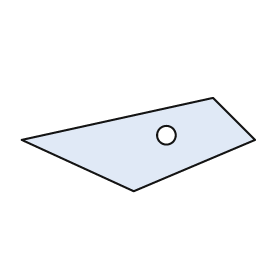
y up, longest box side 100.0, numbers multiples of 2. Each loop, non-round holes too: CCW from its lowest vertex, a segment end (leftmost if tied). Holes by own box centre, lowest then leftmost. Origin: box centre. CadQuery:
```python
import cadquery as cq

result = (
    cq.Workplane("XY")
    .moveTo(-2.0, -20.0)
    .lineTo(50.0, 2.0)
    .lineTo(32.0, 20.0)
    .lineTo(-50.0, 2.0)
    .close()
    .moveTo(12.0, 4.0)
    .circle(4.0)
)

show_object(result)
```